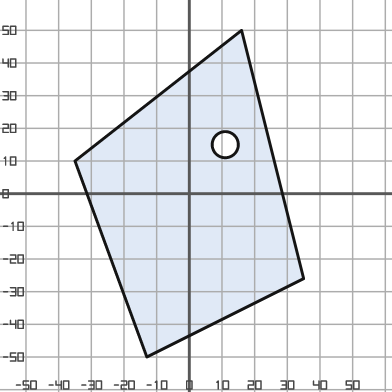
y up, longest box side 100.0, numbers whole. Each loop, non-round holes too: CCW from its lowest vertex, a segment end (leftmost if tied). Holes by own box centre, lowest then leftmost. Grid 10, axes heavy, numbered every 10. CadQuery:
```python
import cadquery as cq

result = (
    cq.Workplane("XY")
    .moveTo(-13.0, -50.0)
    .lineTo(35.0, -26.0)
    .lineTo(16.0, 50.0)
    .lineTo(-35.0, 10.0)
    .close()
    .moveTo(11.0, 15.0)
    .circle(4.0)
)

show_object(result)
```